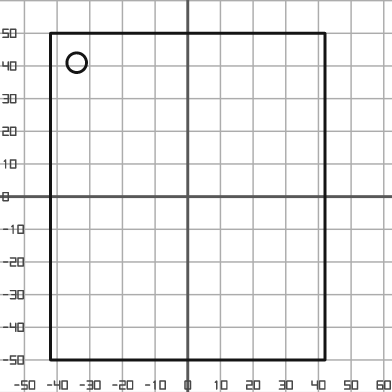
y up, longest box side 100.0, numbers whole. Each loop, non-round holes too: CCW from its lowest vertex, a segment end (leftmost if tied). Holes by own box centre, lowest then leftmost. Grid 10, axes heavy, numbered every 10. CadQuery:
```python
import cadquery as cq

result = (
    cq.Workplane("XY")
    .moveTo(-42.0, -50.0)
    .lineTo(42.0, -50.0)
    .lineTo(42.0, 50.0)
    .lineTo(-42.0, 50.0)
    .close()
    .moveTo(-34.0, 41.0)
    .circle(3.0)
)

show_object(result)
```